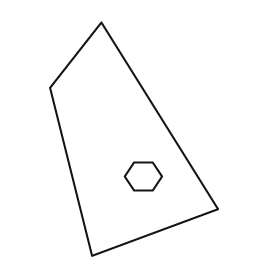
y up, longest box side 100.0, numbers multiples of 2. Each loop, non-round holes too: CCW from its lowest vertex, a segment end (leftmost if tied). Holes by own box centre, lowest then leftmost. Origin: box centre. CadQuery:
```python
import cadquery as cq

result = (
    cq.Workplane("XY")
    .moveTo(-18.0, -50.0)
    .lineTo(36.0, -30.0)
    .lineTo(-14.0, 50.0)
    .lineTo(-36.0, 22.0)
    .close()
    .moveTo(0.0, -22.0)
    .lineTo(8.0, -22.0)
    .lineTo(12.0, -16.0)
    .lineTo(8.0, -10.0)
    .lineTo(0.0, -10.0)
    .lineTo(-4.0, -16.0)
    .close()
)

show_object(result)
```